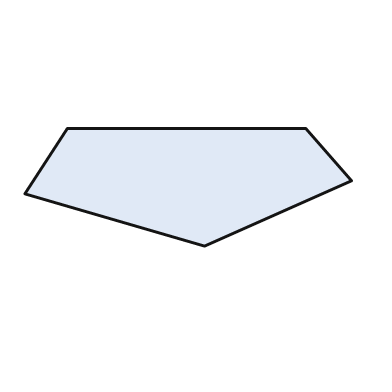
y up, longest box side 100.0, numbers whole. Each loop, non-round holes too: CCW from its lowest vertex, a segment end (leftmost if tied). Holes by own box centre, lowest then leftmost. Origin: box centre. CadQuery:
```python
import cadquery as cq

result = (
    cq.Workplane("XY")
    .moveTo(5.0, -18.0)
    .lineTo(50.0, 2.0)
    .lineTo(36.0, 18.0)
    .lineTo(-37.0, 18.0)
    .lineTo(-50.0, -2.0)
    .close()
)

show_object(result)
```